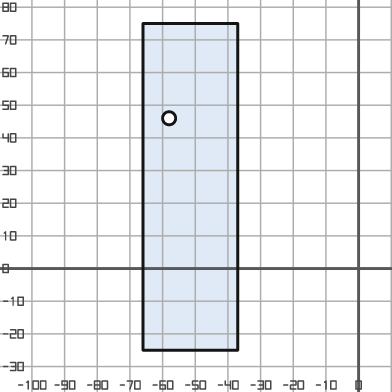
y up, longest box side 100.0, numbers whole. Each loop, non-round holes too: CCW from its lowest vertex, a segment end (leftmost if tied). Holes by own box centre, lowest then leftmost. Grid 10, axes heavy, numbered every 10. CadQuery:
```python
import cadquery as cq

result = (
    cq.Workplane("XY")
    .moveTo(-66.0, -25.0)
    .lineTo(-37.0, -25.0)
    .lineTo(-37.0, 75.0)
    .lineTo(-66.0, 75.0)
    .close()
    .moveTo(-58.0, 46.0)
    .circle(2.0)
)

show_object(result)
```